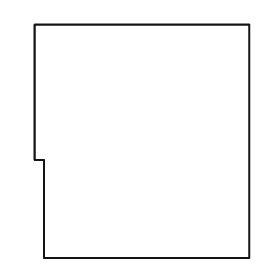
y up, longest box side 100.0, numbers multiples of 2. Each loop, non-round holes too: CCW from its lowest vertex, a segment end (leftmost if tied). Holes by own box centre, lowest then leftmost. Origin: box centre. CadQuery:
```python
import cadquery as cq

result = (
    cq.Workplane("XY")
    .moveTo(-42.0, -50.0)
    .lineTo(46.0, -50.0)
    .lineTo(46.0, 50.0)
    .lineTo(-46.0, 50.0)
    .lineTo(-46.0, -8.0)
    .lineTo(-42.0, -8.0)
    .close()
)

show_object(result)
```